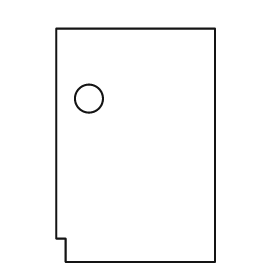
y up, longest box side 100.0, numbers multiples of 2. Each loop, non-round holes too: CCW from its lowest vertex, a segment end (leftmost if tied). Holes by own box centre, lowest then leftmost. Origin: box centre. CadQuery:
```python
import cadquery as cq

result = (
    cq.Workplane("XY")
    .moveTo(-30.0, -50.0)
    .lineTo(34.0, -50.0)
    .lineTo(34.0, 50.0)
    .lineTo(-34.0, 50.0)
    .lineTo(-34.0, -40.0)
    .lineTo(-30.0, -40.0)
    .close()
    .moveTo(-20.0, 20.0)
    .circle(6.0)
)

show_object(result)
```